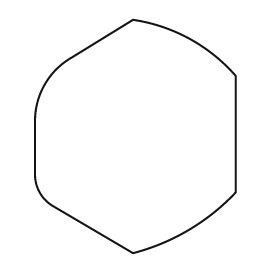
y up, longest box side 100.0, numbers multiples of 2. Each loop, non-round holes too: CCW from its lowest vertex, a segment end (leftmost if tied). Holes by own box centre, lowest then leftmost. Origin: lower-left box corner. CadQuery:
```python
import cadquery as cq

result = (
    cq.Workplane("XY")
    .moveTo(42.0, 0.0)
    .threePointArc((66.0, 10.0), (86.0, 26.0))
    .lineTo(86.0, 76.0)
    .threePointArc((66.0, 92.0), (42.0, 100.0))
    .lineTo(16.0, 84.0)
    .threePointArc((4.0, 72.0), (0.0, 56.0))
    .lineTo(0.0, 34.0)
    .threePointArc((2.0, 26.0), (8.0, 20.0))
    .close()
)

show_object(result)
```